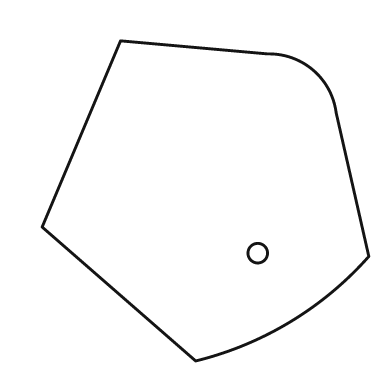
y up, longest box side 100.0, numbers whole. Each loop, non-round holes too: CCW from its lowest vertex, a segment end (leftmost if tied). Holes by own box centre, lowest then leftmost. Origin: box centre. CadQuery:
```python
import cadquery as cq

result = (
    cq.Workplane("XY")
    .moveTo(-3.0, -49.0)
    .threePointArc((26.0, -37.0), (50.0, -17.0))
    .lineTo(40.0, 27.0)
    .threePointArc((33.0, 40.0), (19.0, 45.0))
    .lineTo(-26.0, 49.0)
    .lineTo(-50.0, -8.0)
    .close()
    .moveTo(16.0, -16.0)
    .circle(3.0)
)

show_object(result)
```